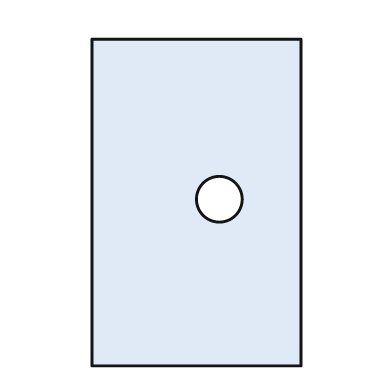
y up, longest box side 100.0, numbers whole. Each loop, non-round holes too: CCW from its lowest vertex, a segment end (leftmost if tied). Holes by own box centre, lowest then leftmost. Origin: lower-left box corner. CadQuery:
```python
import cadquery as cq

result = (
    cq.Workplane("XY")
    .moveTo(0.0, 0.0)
    .lineTo(64.0, 0.0)
    .lineTo(64.0, 100.0)
    .lineTo(0.0, 100.0)
    .close()
    .moveTo(39.0, 51.0)
    .circle(7.0)
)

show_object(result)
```